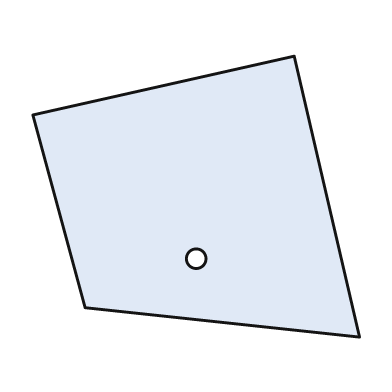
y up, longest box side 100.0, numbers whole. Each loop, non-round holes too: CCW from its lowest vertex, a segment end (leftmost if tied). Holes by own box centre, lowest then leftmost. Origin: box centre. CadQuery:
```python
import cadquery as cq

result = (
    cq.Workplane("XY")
    .moveTo(50.0, -43.0)
    .lineTo(30.0, 43.0)
    .lineTo(-50.0, 25.0)
    .lineTo(-34.0, -34.0)
    .close()
    .moveTo(0.0, -19.0)
    .circle(3.0)
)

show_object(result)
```